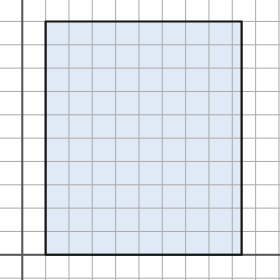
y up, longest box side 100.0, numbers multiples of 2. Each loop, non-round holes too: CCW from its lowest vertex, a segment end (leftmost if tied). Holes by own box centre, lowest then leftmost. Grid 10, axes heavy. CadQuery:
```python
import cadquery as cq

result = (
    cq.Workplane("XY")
    .moveTo(10.0, 0.0)
    .lineTo(94.0, 0.0)
    .lineTo(94.0, 100.0)
    .lineTo(10.0, 100.0)
    .close()
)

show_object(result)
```